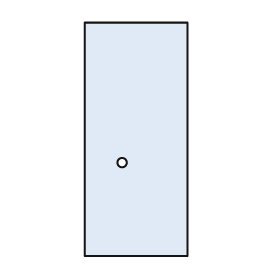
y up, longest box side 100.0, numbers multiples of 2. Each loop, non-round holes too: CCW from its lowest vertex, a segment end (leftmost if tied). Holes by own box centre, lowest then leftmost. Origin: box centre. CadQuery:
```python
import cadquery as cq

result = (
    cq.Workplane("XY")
    .moveTo(-22.0, -50.0)
    .lineTo(22.0, -50.0)
    .lineTo(22.0, 50.0)
    .lineTo(-22.0, 50.0)
    .close()
    .moveTo(-6.0, -10.0)
    .circle(2.0)
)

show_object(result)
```